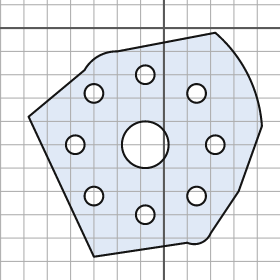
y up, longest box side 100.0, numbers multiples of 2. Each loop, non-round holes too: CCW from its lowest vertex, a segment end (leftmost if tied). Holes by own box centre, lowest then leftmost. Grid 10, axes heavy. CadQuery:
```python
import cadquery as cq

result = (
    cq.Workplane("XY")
    .moveTo(-30.0, -98.0)
    .lineTo(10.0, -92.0)
    .threePointArc((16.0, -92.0), (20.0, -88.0))
    .lineTo(32.0, -70.0)
    .lineTo(42.0, -42.0)
    .threePointArc((36.0, -20.0), (22.0, -2.0))
    .lineTo(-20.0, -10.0)
    .threePointArc((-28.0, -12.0), (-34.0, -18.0))
    .lineTo(-58.0, -38.0)
    .close()
    .moveTo(-8.0, -80.0)
    .circle(4.0)
    .moveTo(-30.0, -72.0)
    .circle(4.0)
    .moveTo(14.0, -72.0)
    .circle(4.0)
    .moveTo(-38.0, -50.0)
    .circle(4.0)
    .moveTo(-8.0, -50.0)
    .circle(10.0)
    .moveTo(22.0, -50.0)
    .circle(4.0)
    .moveTo(-30.0, -28.0)
    .circle(4.0)
    .moveTo(14.0, -28.0)
    .circle(4.0)
    .moveTo(-8.0, -20.0)
    .circle(4.0)
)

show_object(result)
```